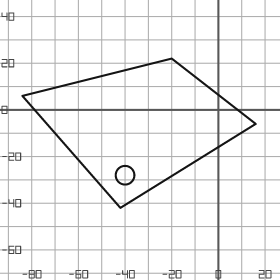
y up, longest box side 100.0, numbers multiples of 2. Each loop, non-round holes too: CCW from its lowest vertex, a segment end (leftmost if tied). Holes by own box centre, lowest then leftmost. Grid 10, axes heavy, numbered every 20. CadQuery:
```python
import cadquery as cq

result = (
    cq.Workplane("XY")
    .moveTo(-42.0, -42.0)
    .lineTo(16.0, -6.0)
    .lineTo(-20.0, 22.0)
    .lineTo(-84.0, 6.0)
    .close()
    .moveTo(-40.0, -28.0)
    .circle(4.0)
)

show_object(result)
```